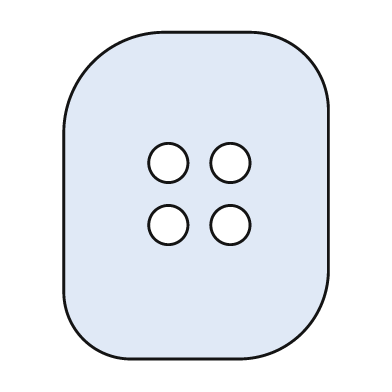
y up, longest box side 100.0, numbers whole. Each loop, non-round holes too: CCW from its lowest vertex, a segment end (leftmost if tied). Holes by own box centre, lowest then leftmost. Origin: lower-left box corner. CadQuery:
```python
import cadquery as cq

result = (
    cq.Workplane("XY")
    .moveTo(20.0, 0.0)
    .lineTo(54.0, 0.0)
    .threePointArc((73.0, 8.0), (81.0, 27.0))
    .lineTo(81.0, 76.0)
    .threePointArc((74.0, 93.0), (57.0, 100.0))
    .lineTo(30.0, 100.0)
    .threePointArc((9.0, 91.0), (0.0, 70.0))
    .lineTo(0.0, 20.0)
    .threePointArc((6.0, 6.0), (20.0, 0.0))
    .close()
    .moveTo(32.0, 41.0)
    .circle(6.0)
    .moveTo(51.0, 41.0)
    .circle(6.0)
    .moveTo(32.0, 60.0)
    .circle(6.0)
    .moveTo(51.0, 60.0)
    .circle(6.0)
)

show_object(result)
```